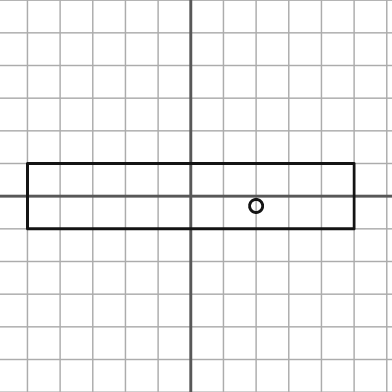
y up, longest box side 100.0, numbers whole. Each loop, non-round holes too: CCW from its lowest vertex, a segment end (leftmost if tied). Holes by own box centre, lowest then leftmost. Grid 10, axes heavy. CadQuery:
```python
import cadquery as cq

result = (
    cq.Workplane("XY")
    .moveTo(-50.0, -10.0)
    .lineTo(50.0, -10.0)
    .lineTo(50.0, 10.0)
    .lineTo(-50.0, 10.0)
    .close()
    .moveTo(20.0, -3.0)
    .circle(2.0)
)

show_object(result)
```